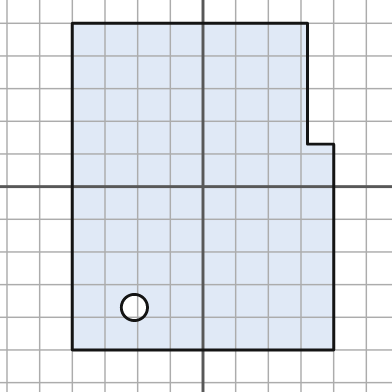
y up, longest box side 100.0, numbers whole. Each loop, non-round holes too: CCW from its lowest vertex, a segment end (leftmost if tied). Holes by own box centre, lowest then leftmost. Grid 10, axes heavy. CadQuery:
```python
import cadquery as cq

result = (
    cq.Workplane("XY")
    .moveTo(-40.0, -50.0)
    .lineTo(40.0, -50.0)
    .lineTo(40.0, 13.0)
    .lineTo(32.0, 13.0)
    .lineTo(32.0, 50.0)
    .lineTo(-40.0, 50.0)
    .close()
    .moveTo(-21.0, -37.0)
    .circle(4.0)
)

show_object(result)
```